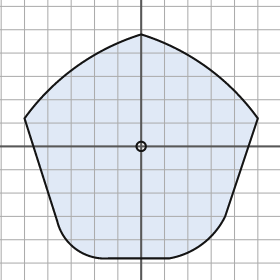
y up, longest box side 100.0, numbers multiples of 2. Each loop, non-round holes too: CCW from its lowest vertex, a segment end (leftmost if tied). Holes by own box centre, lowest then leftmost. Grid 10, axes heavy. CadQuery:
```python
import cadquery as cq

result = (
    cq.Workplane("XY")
    .moveTo(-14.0, -48.0)
    .lineTo(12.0, -48.0)
    .threePointArc((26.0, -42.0), (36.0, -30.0))
    .lineTo(50.0, 12.0)
    .threePointArc((28.0, 34.0), (0.0, 48.0))
    .threePointArc((-28.0, 34.0), (-50.0, 12.0))
    .lineTo(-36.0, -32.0)
    .threePointArc((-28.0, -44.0), (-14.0, -48.0))
    .close()
    .moveTo(0.0, 0.0)
    .circle(2.0)
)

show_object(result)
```